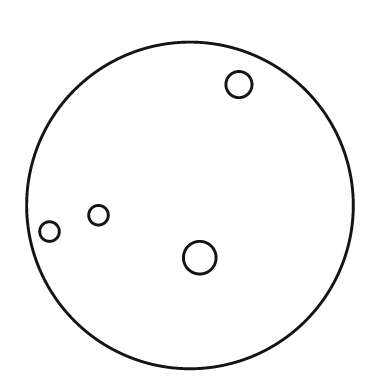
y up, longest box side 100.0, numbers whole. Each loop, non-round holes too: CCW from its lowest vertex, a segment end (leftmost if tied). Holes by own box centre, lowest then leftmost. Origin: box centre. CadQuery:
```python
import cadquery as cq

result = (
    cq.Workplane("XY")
    .moveTo(0.0, 0.0)
    .circle(50.0)
    .moveTo(3.0, -16.0)
    .circle(5.0)
    .moveTo(-43.0, -8.0)
    .circle(3.0)
    .moveTo(-28.0, -3.0)
    .circle(3.0)
    .moveTo(15.0, 37.0)
    .circle(4.0)
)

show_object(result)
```